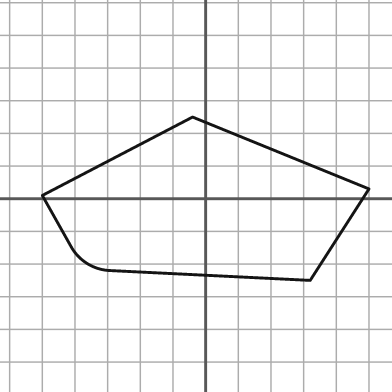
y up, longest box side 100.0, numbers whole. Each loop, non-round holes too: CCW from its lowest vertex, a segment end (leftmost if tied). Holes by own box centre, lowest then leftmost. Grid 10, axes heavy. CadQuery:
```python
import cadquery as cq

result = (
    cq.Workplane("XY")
    .moveTo(32.0, -25.0)
    .lineTo(50.0, 3.0)
    .lineTo(-4.0, 25.0)
    .lineTo(-50.0, 1.0)
    .lineTo(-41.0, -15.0)
    .threePointArc((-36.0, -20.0), (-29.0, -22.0))
    .close()
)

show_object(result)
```